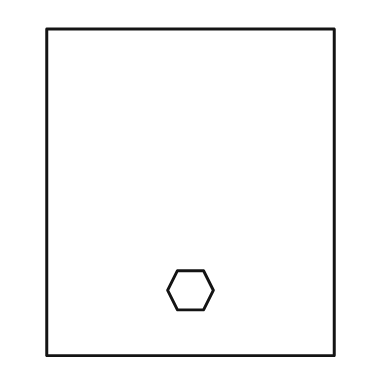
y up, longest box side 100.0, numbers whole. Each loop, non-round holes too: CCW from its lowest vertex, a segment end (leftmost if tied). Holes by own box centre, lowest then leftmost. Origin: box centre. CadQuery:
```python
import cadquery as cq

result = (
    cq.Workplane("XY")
    .moveTo(-44.0, -50.0)
    .lineTo(44.0, -50.0)
    .lineTo(44.0, 50.0)
    .lineTo(-44.0, 50.0)
    .close()
    .moveTo(-4.0, -36.0)
    .lineTo(4.0, -36.0)
    .lineTo(7.0, -30.0)
    .lineTo(4.0, -24.0)
    .lineTo(-4.0, -24.0)
    .lineTo(-7.0, -30.0)
    .close()
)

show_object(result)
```